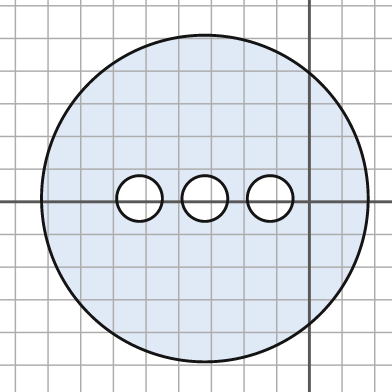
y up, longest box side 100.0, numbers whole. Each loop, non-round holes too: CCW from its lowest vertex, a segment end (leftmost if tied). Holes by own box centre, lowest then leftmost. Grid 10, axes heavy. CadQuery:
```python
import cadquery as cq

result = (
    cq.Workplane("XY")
    .moveTo(-32.0, 1.0)
    .circle(50.0)
    .moveTo(-52.0, 1.0)
    .circle(7.0)
    .moveTo(-32.0, 1.0)
    .circle(7.0)
    .moveTo(-12.0, 1.0)
    .circle(7.0)
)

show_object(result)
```